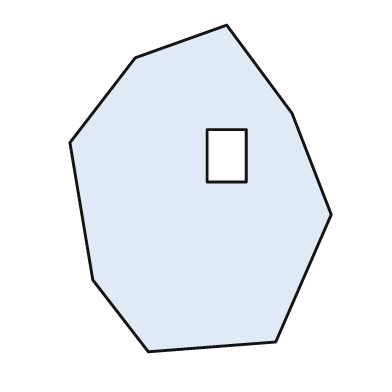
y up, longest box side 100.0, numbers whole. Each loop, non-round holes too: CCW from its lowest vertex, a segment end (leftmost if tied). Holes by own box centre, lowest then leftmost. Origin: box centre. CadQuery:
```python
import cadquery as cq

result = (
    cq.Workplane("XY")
    .moveTo(-16.0, -50.0)
    .lineTo(23.0, -47.0)
    .lineTo(40.0, -8.0)
    .lineTo(28.0, 23.0)
    .lineTo(8.0, 50.0)
    .lineTo(-20.0, 40.0)
    .lineTo(-40.0, 14.0)
    .lineTo(-33.0, -28.0)
    .close()
    .moveTo(2.0, 2.0)
    .lineTo(14.0, 2.0)
    .lineTo(14.0, 18.0)
    .lineTo(2.0, 18.0)
    .close()
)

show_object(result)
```